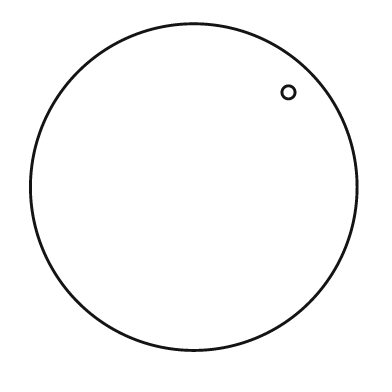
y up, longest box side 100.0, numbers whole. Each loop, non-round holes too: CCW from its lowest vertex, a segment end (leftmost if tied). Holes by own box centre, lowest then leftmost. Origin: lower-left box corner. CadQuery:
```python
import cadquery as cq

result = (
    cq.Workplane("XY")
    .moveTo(50.0, 50.0)
    .circle(50.0)
    .moveTo(79.0, 79.0)
    .circle(2.0)
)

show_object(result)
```